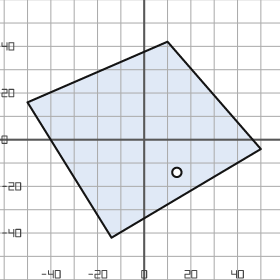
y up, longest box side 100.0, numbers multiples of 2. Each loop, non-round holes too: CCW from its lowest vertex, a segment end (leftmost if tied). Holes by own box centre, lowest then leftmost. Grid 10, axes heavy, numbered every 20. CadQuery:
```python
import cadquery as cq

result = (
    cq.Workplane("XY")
    .moveTo(-14.0, -42.0)
    .lineTo(50.0, -4.0)
    .lineTo(10.0, 42.0)
    .lineTo(-50.0, 16.0)
    .close()
    .moveTo(14.0, -14.0)
    .circle(2.0)
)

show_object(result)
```